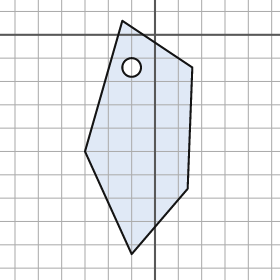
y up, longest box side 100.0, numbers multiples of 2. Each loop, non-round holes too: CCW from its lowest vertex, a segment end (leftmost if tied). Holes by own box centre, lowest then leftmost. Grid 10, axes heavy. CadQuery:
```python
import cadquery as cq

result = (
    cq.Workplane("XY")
    .moveTo(-10.0, -94.0)
    .lineTo(14.0, -66.0)
    .lineTo(16.0, -14.0)
    .lineTo(-14.0, 6.0)
    .lineTo(-30.0, -50.0)
    .close()
    .moveTo(-10.0, -14.0)
    .circle(4.0)
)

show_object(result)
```